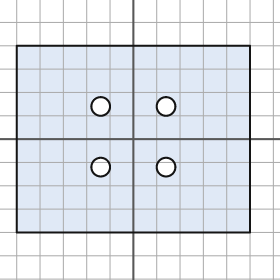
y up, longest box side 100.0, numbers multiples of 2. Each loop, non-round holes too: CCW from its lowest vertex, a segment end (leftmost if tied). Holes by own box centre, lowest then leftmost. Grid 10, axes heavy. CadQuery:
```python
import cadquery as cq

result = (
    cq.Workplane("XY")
    .moveTo(-50.0, -40.0)
    .lineTo(50.0, -40.0)
    .lineTo(50.0, 40.0)
    .lineTo(-50.0, 40.0)
    .close()
    .moveTo(-14.0, -12.0)
    .circle(4.0)
    .moveTo(14.0, -12.0)
    .circle(4.0)
    .moveTo(-14.0, 14.0)
    .circle(4.0)
    .moveTo(14.0, 14.0)
    .circle(4.0)
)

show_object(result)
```